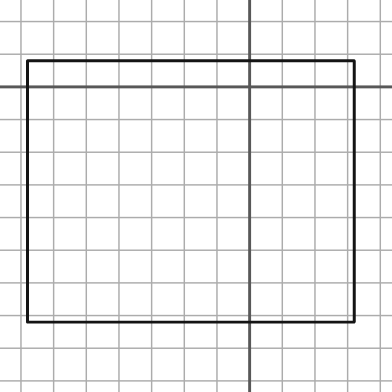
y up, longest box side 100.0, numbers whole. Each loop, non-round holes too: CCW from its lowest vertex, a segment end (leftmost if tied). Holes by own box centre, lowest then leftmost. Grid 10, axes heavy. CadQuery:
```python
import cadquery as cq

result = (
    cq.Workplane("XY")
    .moveTo(-68.0, -72.0)
    .lineTo(32.0, -72.0)
    .lineTo(32.0, 8.0)
    .lineTo(-68.0, 8.0)
    .close()
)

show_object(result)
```